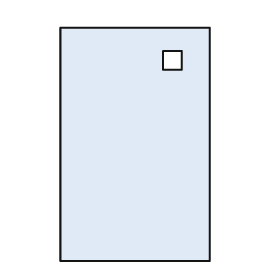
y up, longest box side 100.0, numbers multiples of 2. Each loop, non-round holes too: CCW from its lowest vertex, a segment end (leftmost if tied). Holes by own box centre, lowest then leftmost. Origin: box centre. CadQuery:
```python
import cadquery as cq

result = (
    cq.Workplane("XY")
    .moveTo(-32.0, -50.0)
    .lineTo(32.0, -50.0)
    .lineTo(32.0, 50.0)
    .lineTo(-32.0, 50.0)
    .close()
    .moveTo(12.0, 32.0)
    .lineTo(20.0, 32.0)
    .lineTo(20.0, 40.0)
    .lineTo(12.0, 40.0)
    .close()
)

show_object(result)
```